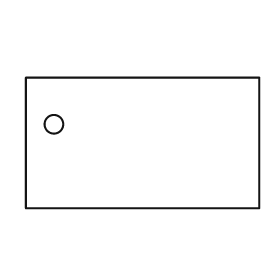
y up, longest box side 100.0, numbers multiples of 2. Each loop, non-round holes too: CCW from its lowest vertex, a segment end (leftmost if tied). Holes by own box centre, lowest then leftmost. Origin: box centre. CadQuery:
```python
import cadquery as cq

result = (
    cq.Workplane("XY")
    .moveTo(-50.0, -28.0)
    .lineTo(50.0, -28.0)
    .lineTo(50.0, 28.0)
    .lineTo(-50.0, 28.0)
    .close()
    .moveTo(-38.0, 8.0)
    .circle(4.0)
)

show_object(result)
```